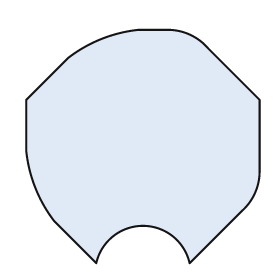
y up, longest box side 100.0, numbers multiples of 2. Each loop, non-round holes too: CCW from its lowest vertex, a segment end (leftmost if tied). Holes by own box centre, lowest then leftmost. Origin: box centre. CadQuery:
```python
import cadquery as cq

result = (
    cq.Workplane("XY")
    .moveTo(-20.0, -50.0)
    .threePointArc((0.0, -34.0), (20.0, -50.0))
    .lineTo(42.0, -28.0)
    .threePointArc((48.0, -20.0), (50.0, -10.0))
    .lineTo(50.0, 20.0)
    .lineTo(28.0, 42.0)
    .threePointArc((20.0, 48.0), (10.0, 50.0))
    .lineTo(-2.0, 50.0)
    .threePointArc((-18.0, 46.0), (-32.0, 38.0))
    .lineTo(-50.0, 20.0)
    .lineTo(-50.0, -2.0)
    .threePointArc((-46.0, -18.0), (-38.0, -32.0))
    .close()
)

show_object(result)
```